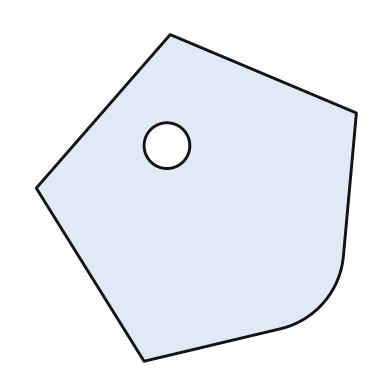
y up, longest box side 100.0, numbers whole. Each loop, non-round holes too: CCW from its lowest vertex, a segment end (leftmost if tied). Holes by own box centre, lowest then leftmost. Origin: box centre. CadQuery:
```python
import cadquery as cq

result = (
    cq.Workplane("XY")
    .moveTo(-16.0, -50.0)
    .lineTo(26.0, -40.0)
    .threePointArc((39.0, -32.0), (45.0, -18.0))
    .lineTo(49.0, 26.0)
    .lineTo(-8.0, 50.0)
    .lineTo(-49.0, 3.0)
    .close()
    .moveTo(-9.0, 16.0)
    .circle(7.0)
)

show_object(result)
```